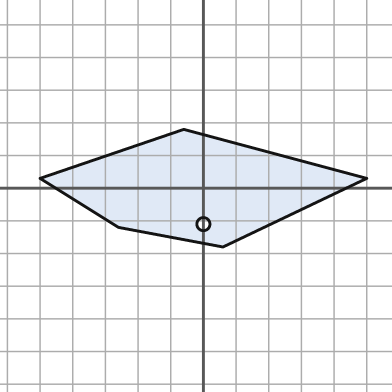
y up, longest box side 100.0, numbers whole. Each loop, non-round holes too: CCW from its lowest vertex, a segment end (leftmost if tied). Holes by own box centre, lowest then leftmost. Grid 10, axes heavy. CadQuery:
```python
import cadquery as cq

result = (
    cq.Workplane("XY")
    .moveTo(6.0, -18.0)
    .lineTo(50.0, 3.0)
    .lineTo(-6.0, 18.0)
    .lineTo(-50.0, 3.0)
    .lineTo(-26.0, -12.0)
    .close()
    .moveTo(0.0, -11.0)
    .circle(2.0)
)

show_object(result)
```